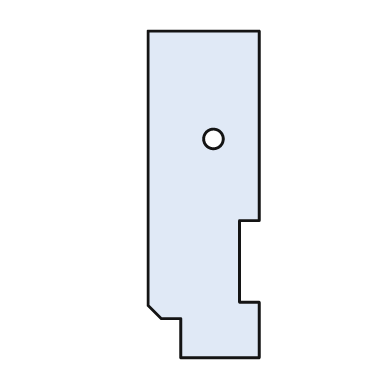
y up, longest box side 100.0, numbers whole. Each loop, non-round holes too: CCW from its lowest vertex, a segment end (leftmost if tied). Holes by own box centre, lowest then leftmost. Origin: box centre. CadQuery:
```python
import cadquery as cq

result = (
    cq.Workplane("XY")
    .moveTo(-7.0, -50.0)
    .lineTo(17.0, -50.0)
    .lineTo(17.0, -33.0)
    .lineTo(11.0, -33.0)
    .lineTo(11.0, -8.0)
    .lineTo(17.0, -8.0)
    .lineTo(17.0, 50.0)
    .lineTo(-17.0, 50.0)
    .lineTo(-17.0, -34.0)
    .lineTo(-13.0, -38.0)
    .lineTo(-7.0, -38.0)
    .close()
    .moveTo(3.0, 17.0)
    .circle(3.0)
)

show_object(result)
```